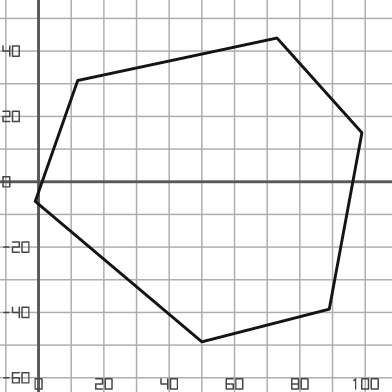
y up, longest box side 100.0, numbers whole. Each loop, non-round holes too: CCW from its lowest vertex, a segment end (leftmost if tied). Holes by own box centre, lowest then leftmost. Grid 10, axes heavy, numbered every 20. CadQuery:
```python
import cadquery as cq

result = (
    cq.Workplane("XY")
    .moveTo(50.0, -49.0)
    .lineTo(89.0, -39.0)
    .lineTo(99.0, 15.0)
    .lineTo(73.0, 44.0)
    .lineTo(12.0, 31.0)
    .lineTo(-1.0, -6.0)
    .close()
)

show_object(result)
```